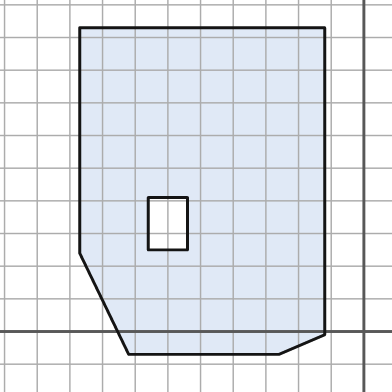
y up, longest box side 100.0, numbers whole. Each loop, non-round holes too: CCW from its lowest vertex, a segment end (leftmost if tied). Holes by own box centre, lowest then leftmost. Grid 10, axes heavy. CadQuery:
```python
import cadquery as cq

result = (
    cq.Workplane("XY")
    .moveTo(-72.0, -7.0)
    .lineTo(-26.0, -7.0)
    .lineTo(-12.0, -1.0)
    .lineTo(-12.0, 93.0)
    .lineTo(-87.0, 93.0)
    .lineTo(-87.0, 24.0)
    .close()
    .moveTo(-66.0, 25.0)
    .lineTo(-54.0, 25.0)
    .lineTo(-54.0, 41.0)
    .lineTo(-66.0, 41.0)
    .close()
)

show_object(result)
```